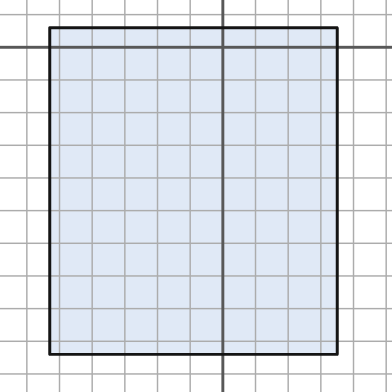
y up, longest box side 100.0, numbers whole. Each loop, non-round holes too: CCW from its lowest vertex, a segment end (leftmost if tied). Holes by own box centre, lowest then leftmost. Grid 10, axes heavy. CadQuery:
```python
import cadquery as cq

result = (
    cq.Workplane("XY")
    .moveTo(-53.0, -94.0)
    .lineTo(35.0, -94.0)
    .lineTo(35.0, 6.0)
    .lineTo(-53.0, 6.0)
    .close()
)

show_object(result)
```